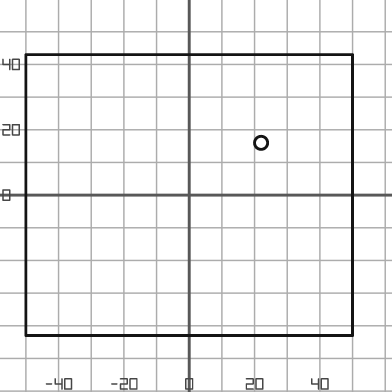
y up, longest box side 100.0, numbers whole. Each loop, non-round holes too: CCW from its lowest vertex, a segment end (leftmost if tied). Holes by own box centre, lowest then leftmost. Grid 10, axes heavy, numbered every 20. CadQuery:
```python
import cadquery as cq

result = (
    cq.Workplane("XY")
    .moveTo(-50.0, -43.0)
    .lineTo(50.0, -43.0)
    .lineTo(50.0, 43.0)
    .lineTo(-50.0, 43.0)
    .close()
    .moveTo(22.0, 16.0)
    .circle(2.0)
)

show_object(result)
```